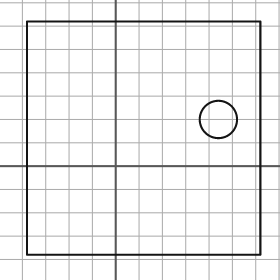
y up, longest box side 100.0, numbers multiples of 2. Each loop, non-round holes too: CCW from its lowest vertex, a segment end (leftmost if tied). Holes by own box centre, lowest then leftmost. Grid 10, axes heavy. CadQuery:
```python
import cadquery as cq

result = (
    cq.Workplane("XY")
    .moveTo(-38.0, -38.0)
    .lineTo(62.0, -38.0)
    .lineTo(62.0, 62.0)
    .lineTo(-38.0, 62.0)
    .close()
    .moveTo(44.0, 20.0)
    .circle(8.0)
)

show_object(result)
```